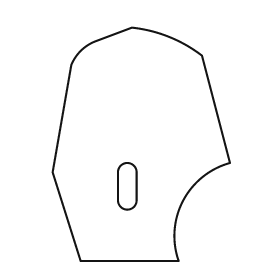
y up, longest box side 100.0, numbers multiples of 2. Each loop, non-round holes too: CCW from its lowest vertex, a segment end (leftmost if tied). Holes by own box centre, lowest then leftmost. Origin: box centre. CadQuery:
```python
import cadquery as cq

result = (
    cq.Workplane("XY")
    .moveTo(-26.0, -50.0)
    .lineTo(16.0, -50.0)
    .threePointArc((18.0, -24.0), (38.0, -8.0))
    .lineTo(26.0, 38.0)
    .threePointArc((12.0, 46.0), (-4.0, 50.0))
    .lineTo(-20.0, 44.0)
    .threePointArc((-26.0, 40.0), (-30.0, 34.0))
    .lineTo(-38.0, -12.0)
    .close()
    .moveTo(-10.0, -24.0)
    .threePointArc((-6.0, -28.0), (-2.0, -24.0))
    .lineTo(-2.0, -12.0)
    .threePointArc((-6.0, -8.0), (-10.0, -12.0))
    .close()
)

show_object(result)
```